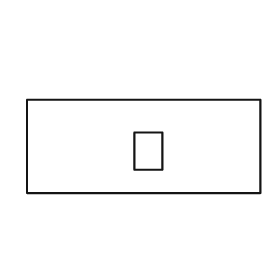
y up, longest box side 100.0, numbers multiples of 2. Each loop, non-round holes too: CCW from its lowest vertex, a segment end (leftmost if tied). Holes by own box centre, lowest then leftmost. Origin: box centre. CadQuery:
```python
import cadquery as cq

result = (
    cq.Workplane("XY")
    .moveTo(-50.0, -20.0)
    .lineTo(50.0, -20.0)
    .lineTo(50.0, 20.0)
    .lineTo(-50.0, 20.0)
    .close()
    .moveTo(-4.0, -10.0)
    .lineTo(8.0, -10.0)
    .lineTo(8.0, 6.0)
    .lineTo(-4.0, 6.0)
    .close()
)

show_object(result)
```